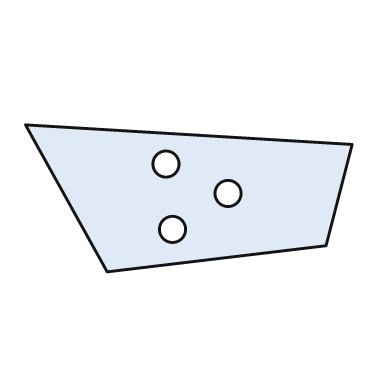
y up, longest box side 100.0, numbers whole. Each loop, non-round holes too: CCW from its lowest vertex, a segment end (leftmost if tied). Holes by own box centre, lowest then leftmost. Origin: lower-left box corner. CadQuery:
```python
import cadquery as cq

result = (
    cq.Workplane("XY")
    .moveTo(25.0, 0.0)
    .lineTo(92.0, 8.0)
    .lineTo(100.0, 39.0)
    .lineTo(0.0, 45.0)
    .close()
    .moveTo(45.0, 13.0)
    .circle(4.0)
    .moveTo(62.0, 24.0)
    .circle(4.0)
    .moveTo(43.0, 33.0)
    .circle(4.0)
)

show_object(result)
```